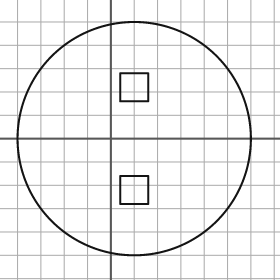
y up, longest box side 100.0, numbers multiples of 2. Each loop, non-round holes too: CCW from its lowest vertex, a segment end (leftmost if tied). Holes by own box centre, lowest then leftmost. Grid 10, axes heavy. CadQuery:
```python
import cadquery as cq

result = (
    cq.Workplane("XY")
    .moveTo(10.0, 0.0)
    .circle(50.0)
    .moveTo(4.0, -28.0)
    .lineTo(16.0, -28.0)
    .lineTo(16.0, -16.0)
    .lineTo(4.0, -16.0)
    .close()
    .moveTo(4.0, 16.0)
    .lineTo(16.0, 16.0)
    .lineTo(16.0, 28.0)
    .lineTo(4.0, 28.0)
    .close()
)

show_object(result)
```